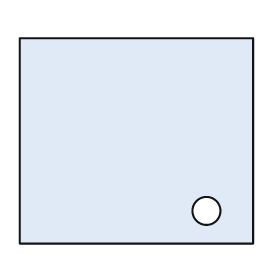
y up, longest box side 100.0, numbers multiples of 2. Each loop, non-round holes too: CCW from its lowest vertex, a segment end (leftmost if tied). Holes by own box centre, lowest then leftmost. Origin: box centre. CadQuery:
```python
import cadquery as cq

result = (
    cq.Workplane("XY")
    .moveTo(-50.0, -44.0)
    .lineTo(50.0, -44.0)
    .lineTo(50.0, 44.0)
    .lineTo(-50.0, 44.0)
    .close()
    .moveTo(30.0, -30.0)
    .circle(6.0)
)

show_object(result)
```